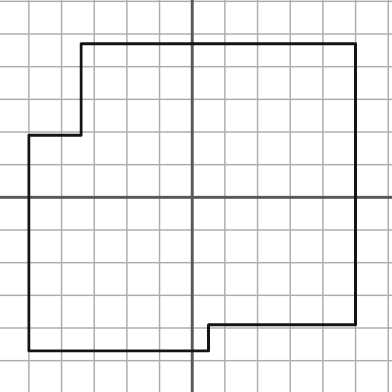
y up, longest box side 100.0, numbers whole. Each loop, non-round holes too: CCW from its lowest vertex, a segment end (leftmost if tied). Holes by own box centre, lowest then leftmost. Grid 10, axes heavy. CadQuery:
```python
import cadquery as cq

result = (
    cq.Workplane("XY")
    .moveTo(-50.0, -47.0)
    .lineTo(5.0, -47.0)
    .lineTo(5.0, -39.0)
    .lineTo(50.0, -39.0)
    .lineTo(50.0, 47.0)
    .lineTo(-34.0, 47.0)
    .lineTo(-34.0, 19.0)
    .lineTo(-50.0, 19.0)
    .close()
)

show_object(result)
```